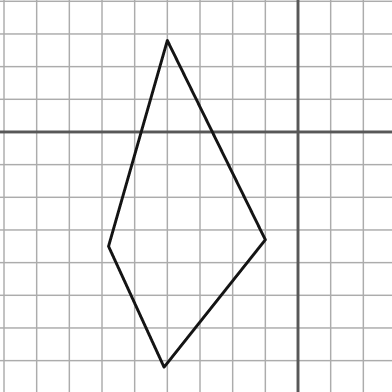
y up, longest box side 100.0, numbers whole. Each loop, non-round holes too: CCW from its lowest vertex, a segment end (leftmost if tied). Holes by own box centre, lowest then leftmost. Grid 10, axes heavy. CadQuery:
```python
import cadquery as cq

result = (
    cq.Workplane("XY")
    .moveTo(-41.0, -72.0)
    .lineTo(-10.0, -33.0)
    .lineTo(-40.0, 28.0)
    .lineTo(-58.0, -35.0)
    .close()
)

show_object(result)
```